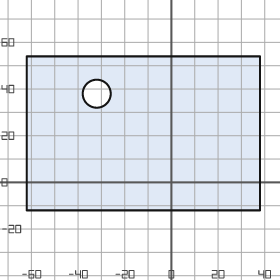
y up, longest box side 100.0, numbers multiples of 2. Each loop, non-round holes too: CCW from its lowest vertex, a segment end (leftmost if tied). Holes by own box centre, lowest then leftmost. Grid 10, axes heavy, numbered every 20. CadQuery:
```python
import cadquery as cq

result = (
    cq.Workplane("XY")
    .moveTo(-62.0, -12.0)
    .lineTo(38.0, -12.0)
    .lineTo(38.0, 54.0)
    .lineTo(-62.0, 54.0)
    .close()
    .moveTo(-32.0, 38.0)
    .circle(6.0)
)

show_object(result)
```